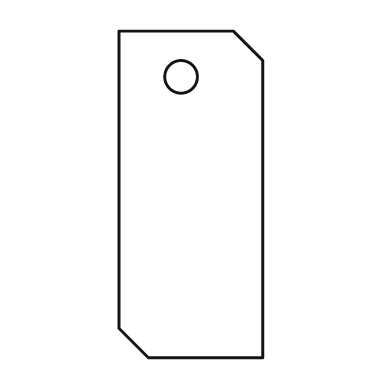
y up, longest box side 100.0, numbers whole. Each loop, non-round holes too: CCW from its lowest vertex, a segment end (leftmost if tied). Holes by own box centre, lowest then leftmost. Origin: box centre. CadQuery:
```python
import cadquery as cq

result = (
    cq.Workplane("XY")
    .moveTo(-13.0, -50.0)
    .lineTo(22.0, -50.0)
    .lineTo(22.0, 41.0)
    .lineTo(13.0, 50.0)
    .lineTo(-22.0, 50.0)
    .lineTo(-22.0, -41.0)
    .close()
    .moveTo(-3.0, 36.0)
    .circle(5.0)
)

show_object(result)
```